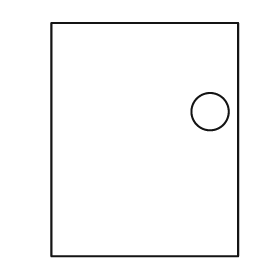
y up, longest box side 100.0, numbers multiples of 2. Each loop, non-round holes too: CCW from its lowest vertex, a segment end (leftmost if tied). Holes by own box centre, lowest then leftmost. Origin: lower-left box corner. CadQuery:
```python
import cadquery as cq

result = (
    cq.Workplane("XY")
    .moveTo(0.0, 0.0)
    .lineTo(80.0, 0.0)
    .lineTo(80.0, 100.0)
    .lineTo(0.0, 100.0)
    .close()
    .moveTo(68.0, 62.0)
    .circle(8.0)
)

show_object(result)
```